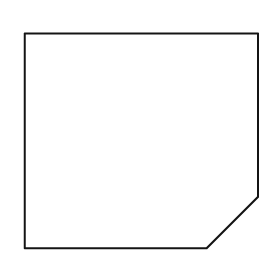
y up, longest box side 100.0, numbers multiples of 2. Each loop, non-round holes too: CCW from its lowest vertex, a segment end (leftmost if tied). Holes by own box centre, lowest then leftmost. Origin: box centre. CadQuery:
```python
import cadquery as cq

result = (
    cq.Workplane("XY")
    .moveTo(-50.0, -46.0)
    .lineTo(28.0, -46.0)
    .lineTo(50.0, -24.0)
    .lineTo(50.0, 46.0)
    .lineTo(-50.0, 46.0)
    .close()
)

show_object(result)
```